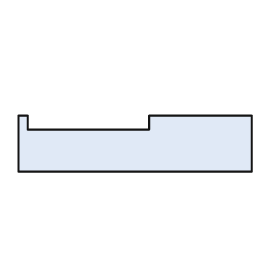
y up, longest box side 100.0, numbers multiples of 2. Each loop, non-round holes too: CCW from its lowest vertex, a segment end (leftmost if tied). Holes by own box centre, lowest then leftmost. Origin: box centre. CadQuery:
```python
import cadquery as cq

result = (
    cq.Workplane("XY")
    .moveTo(-50.0, -12.0)
    .lineTo(50.0, -12.0)
    .lineTo(50.0, 12.0)
    .lineTo(6.0, 12.0)
    .lineTo(6.0, 6.0)
    .lineTo(-46.0, 6.0)
    .lineTo(-46.0, 12.0)
    .lineTo(-50.0, 12.0)
    .close()
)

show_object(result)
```